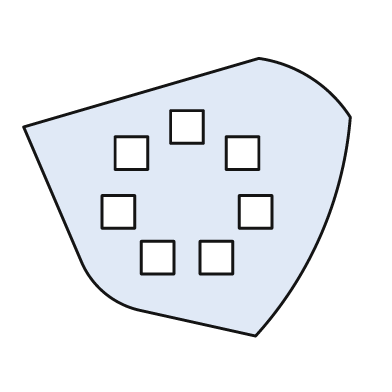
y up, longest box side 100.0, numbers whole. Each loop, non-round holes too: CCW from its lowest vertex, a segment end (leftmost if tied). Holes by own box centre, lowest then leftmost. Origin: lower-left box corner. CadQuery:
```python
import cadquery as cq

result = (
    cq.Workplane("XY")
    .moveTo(71.0, 0.0)
    .threePointArc((91.0, 31.0), (100.0, 67.0))
    .threePointArc((88.0, 79.0), (72.0, 85.0))
    .lineTo(0.0, 64.0)
    .lineTo(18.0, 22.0)
    .threePointArc((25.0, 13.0), (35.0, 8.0))
    .close()
    .moveTo(36.0, 19.0)
    .lineTo(46.0, 19.0)
    .lineTo(46.0, 29.0)
    .lineTo(36.0, 29.0)
    .close()
    .moveTo(54.0, 19.0)
    .lineTo(64.0, 19.0)
    .lineTo(64.0, 29.0)
    .lineTo(54.0, 29.0)
    .close()
    .moveTo(24.0, 33.0)
    .lineTo(34.0, 33.0)
    .lineTo(34.0, 43.0)
    .lineTo(24.0, 43.0)
    .close()
    .moveTo(66.0, 33.0)
    .lineTo(76.0, 33.0)
    .lineTo(76.0, 43.0)
    .lineTo(66.0, 43.0)
    .close()
    .moveTo(28.0, 51.0)
    .lineTo(38.0, 51.0)
    .lineTo(38.0, 61.0)
    .lineTo(28.0, 61.0)
    .close()
    .moveTo(62.0, 51.0)
    .lineTo(72.0, 51.0)
    .lineTo(72.0, 61.0)
    .lineTo(62.0, 61.0)
    .close()
    .moveTo(45.0, 59.0)
    .lineTo(55.0, 59.0)
    .lineTo(55.0, 69.0)
    .lineTo(45.0, 69.0)
    .close()
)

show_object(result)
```